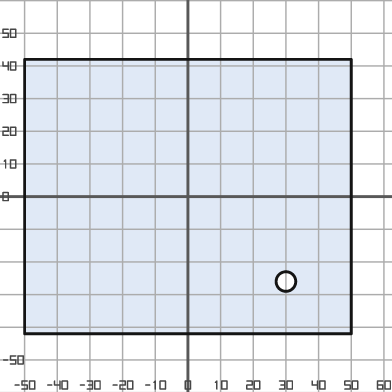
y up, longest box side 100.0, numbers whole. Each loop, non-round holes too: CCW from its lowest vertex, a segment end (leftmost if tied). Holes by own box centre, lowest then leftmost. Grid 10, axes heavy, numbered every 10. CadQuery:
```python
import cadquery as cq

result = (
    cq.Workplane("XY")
    .moveTo(-50.0, -42.0)
    .lineTo(50.0, -42.0)
    .lineTo(50.0, 42.0)
    .lineTo(-50.0, 42.0)
    .close()
    .moveTo(30.0, -26.0)
    .circle(3.0)
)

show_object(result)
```